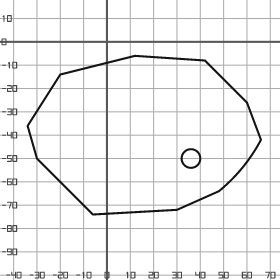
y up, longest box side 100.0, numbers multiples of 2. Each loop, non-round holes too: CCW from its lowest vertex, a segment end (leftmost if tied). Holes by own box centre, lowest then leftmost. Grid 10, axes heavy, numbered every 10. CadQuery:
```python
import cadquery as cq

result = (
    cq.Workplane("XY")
    .moveTo(-6.0, -74.0)
    .lineTo(30.0, -72.0)
    .lineTo(48.0, -64.0)
    .threePointArc((58.0, -54.0), (66.0, -42.0))
    .lineTo(60.0, -26.0)
    .lineTo(42.0, -8.0)
    .lineTo(12.0, -6.0)
    .lineTo(-20.0, -14.0)
    .lineTo(-34.0, -36.0)
    .lineTo(-30.0, -50.0)
    .close()
    .moveTo(36.0, -50.0)
    .circle(4.0)
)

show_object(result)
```